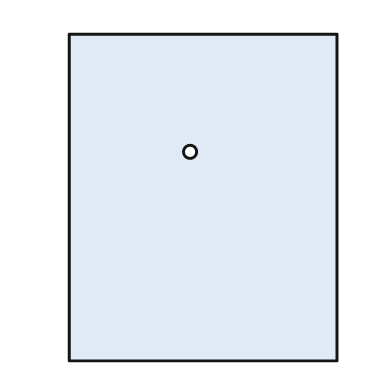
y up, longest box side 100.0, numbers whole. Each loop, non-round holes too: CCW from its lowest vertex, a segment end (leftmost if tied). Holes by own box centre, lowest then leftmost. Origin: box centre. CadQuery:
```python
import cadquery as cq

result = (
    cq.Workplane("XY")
    .moveTo(-41.0, -50.0)
    .lineTo(41.0, -50.0)
    .lineTo(41.0, 50.0)
    .lineTo(-41.0, 50.0)
    .close()
    .moveTo(-4.0, 14.0)
    .circle(2.0)
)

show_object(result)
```